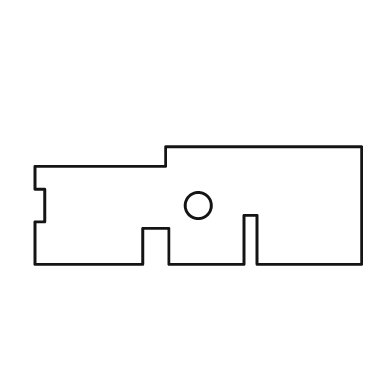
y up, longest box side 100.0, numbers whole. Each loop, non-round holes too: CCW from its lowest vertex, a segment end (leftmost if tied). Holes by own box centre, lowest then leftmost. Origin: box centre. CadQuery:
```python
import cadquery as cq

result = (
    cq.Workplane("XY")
    .moveTo(-50.0, -18.0)
    .lineTo(-17.0, -18.0)
    .lineTo(-17.0, -7.0)
    .lineTo(-9.0, -7.0)
    .lineTo(-9.0, -18.0)
    .lineTo(14.0, -18.0)
    .lineTo(14.0, -3.0)
    .lineTo(18.0, -3.0)
    .lineTo(18.0, -18.0)
    .lineTo(50.0, -18.0)
    .lineTo(50.0, 18.0)
    .lineTo(-10.0, 18.0)
    .lineTo(-10.0, 12.0)
    .lineTo(-50.0, 12.0)
    .lineTo(-50.0, 5.0)
    .lineTo(-47.0, 5.0)
    .lineTo(-47.0, -5.0)
    .lineTo(-50.0, -5.0)
    .close()
    .moveTo(0.0, 0.0)
    .circle(4.0)
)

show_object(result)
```